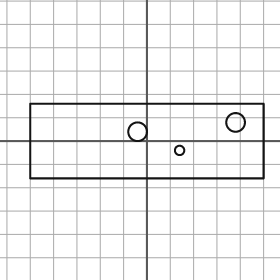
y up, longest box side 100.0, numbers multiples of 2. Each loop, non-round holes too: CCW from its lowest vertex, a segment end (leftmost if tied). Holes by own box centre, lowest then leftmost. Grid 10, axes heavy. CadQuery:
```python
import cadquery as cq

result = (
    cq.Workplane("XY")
    .moveTo(-50.0, -16.0)
    .lineTo(50.0, -16.0)
    .lineTo(50.0, 16.0)
    .lineTo(-50.0, 16.0)
    .close()
    .moveTo(14.0, -4.0)
    .circle(2.0)
    .moveTo(-4.0, 4.0)
    .circle(4.0)
    .moveTo(38.0, 8.0)
    .circle(4.0)
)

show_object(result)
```